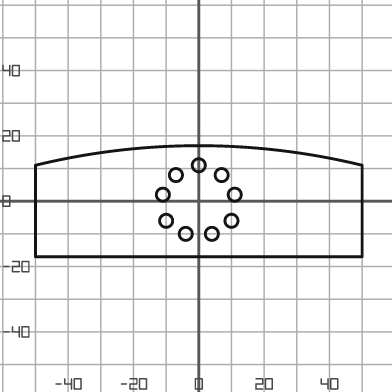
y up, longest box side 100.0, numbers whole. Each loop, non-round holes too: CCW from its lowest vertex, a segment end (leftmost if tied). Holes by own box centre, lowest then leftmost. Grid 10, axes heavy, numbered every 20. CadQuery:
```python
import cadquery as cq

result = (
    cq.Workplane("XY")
    .moveTo(-50.0, -17.0)
    .lineTo(50.0, -17.0)
    .lineTo(50.0, 11.0)
    .threePointArc((0.0, 17.0), (-50.0, 11.0))
    .close()
    .moveTo(-4.0, -10.0)
    .circle(2.0)
    .moveTo(4.0, -10.0)
    .circle(2.0)
    .moveTo(-10.0, -6.0)
    .circle(2.0)
    .moveTo(10.0, -6.0)
    .circle(2.0)
    .moveTo(-11.0, 2.0)
    .circle(2.0)
    .moveTo(11.0, 2.0)
    .circle(2.0)
    .moveTo(-7.0, 8.0)
    .circle(2.0)
    .moveTo(7.0, 8.0)
    .circle(2.0)
    .moveTo(0.0, 11.0)
    .circle(2.0)
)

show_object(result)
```